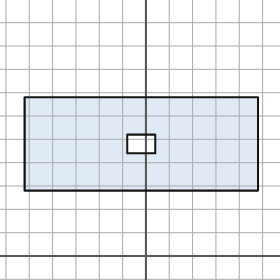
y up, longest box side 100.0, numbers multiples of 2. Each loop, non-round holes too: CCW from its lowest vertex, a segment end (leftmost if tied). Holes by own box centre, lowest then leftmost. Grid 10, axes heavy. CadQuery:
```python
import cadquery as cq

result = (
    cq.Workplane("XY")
    .moveTo(-52.0, 28.0)
    .lineTo(48.0, 28.0)
    .lineTo(48.0, 68.0)
    .lineTo(-52.0, 68.0)
    .close()
    .moveTo(-8.0, 44.0)
    .lineTo(4.0, 44.0)
    .lineTo(4.0, 52.0)
    .lineTo(-8.0, 52.0)
    .close()
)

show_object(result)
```